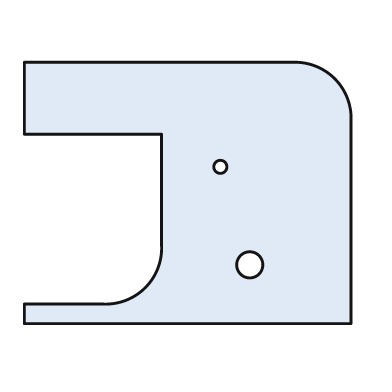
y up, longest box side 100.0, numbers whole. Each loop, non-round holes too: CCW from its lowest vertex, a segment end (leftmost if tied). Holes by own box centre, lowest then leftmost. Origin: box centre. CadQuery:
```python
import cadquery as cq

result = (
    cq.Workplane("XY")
    .moveTo(-50.0, -40.0)
    .lineTo(50.0, -40.0)
    .lineTo(50.0, 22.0)
    .threePointArc((45.0, 35.0), (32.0, 40.0))
    .lineTo(-50.0, 40.0)
    .lineTo(-50.0, 18.0)
    .lineTo(-8.0, 18.0)
    .lineTo(-8.0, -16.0)
    .threePointArc((-13.0, -29.0), (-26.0, -34.0))
    .lineTo(-50.0, -34.0)
    .close()
    .moveTo(19.0, -22.0)
    .circle(4.0)
    .moveTo(10.0, 8.0)
    .circle(2.0)
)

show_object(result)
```